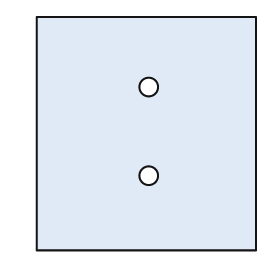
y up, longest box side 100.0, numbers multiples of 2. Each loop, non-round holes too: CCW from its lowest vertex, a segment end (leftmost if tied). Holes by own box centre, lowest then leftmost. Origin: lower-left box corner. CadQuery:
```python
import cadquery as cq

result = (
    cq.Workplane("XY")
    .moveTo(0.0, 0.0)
    .lineTo(94.0, 0.0)
    .lineTo(94.0, 100.0)
    .lineTo(0.0, 100.0)
    .close()
    .moveTo(48.0, 32.0)
    .circle(4.0)
    .moveTo(48.0, 70.0)
    .circle(4.0)
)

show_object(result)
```